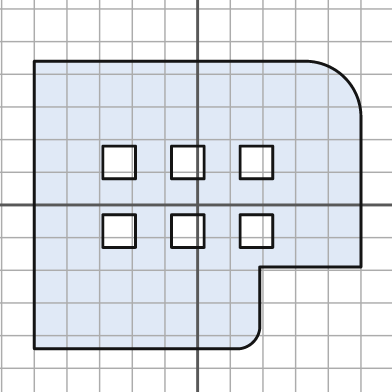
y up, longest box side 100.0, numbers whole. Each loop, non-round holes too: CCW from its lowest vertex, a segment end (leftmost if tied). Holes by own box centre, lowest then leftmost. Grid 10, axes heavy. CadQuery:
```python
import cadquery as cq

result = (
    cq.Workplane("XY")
    .moveTo(-50.0, -44.0)
    .lineTo(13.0, -44.0)
    .threePointArc((17.0, -42.0), (19.0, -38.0))
    .lineTo(19.0, -19.0)
    .lineTo(50.0, -19.0)
    .lineTo(50.0, 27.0)
    .threePointArc((45.0, 39.0), (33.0, 44.0))
    .lineTo(-50.0, 44.0)
    .close()
    .moveTo(-29.0, -13.0)
    .lineTo(-19.0, -13.0)
    .lineTo(-19.0, -3.0)
    .lineTo(-29.0, -3.0)
    .close()
    .moveTo(-8.0, -13.0)
    .lineTo(2.0, -13.0)
    .lineTo(2.0, -3.0)
    .lineTo(-8.0, -3.0)
    .close()
    .moveTo(13.0, -13.0)
    .lineTo(23.0, -13.0)
    .lineTo(23.0, -3.0)
    .lineTo(13.0, -3.0)
    .close()
    .moveTo(-29.0, 8.0)
    .lineTo(-19.0, 8.0)
    .lineTo(-19.0, 18.0)
    .lineTo(-29.0, 18.0)
    .close()
    .moveTo(-8.0, 8.0)
    .lineTo(2.0, 8.0)
    .lineTo(2.0, 18.0)
    .lineTo(-8.0, 18.0)
    .close()
    .moveTo(13.0, 8.0)
    .lineTo(23.0, 8.0)
    .lineTo(23.0, 18.0)
    .lineTo(13.0, 18.0)
    .close()
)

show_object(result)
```